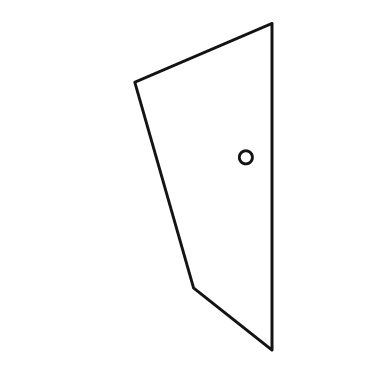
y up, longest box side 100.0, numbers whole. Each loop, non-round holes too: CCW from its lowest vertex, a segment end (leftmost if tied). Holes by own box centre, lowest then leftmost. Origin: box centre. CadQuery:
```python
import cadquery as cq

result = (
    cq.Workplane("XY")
    .moveTo(21.0, -50.0)
    .lineTo(21.0, 50.0)
    .lineTo(-21.0, 32.0)
    .lineTo(-3.0, -31.0)
    .close()
    .moveTo(13.0, 9.0)
    .circle(2.0)
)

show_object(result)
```